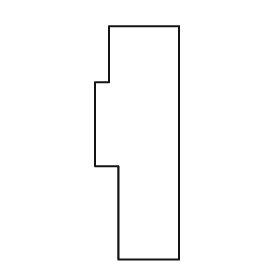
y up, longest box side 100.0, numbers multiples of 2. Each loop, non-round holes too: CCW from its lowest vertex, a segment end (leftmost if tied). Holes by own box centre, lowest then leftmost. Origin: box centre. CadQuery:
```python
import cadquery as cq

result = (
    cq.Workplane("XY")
    .moveTo(-8.0, -50.0)
    .lineTo(18.0, -50.0)
    .lineTo(18.0, 50.0)
    .lineTo(-12.0, 50.0)
    .lineTo(-12.0, 26.0)
    .lineTo(-18.0, 26.0)
    .lineTo(-18.0, -10.0)
    .lineTo(-8.0, -10.0)
    .close()
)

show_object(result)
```